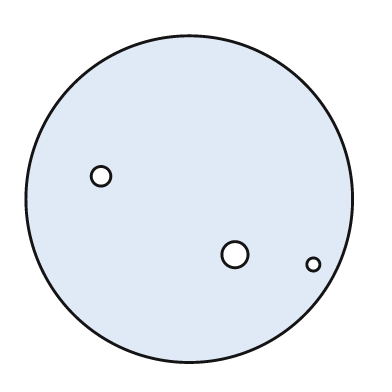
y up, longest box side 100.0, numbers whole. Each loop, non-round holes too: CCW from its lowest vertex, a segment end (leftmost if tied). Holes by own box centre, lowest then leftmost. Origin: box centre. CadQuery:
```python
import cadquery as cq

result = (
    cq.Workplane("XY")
    .moveTo(0.0, 0.0)
    .circle(50.0)
    .moveTo(38.0, -20.0)
    .circle(2.0)
    .moveTo(14.0, -17.0)
    .circle(4.0)
    .moveTo(-27.0, 7.0)
    .circle(3.0)
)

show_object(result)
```